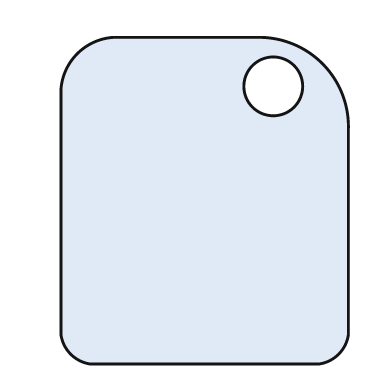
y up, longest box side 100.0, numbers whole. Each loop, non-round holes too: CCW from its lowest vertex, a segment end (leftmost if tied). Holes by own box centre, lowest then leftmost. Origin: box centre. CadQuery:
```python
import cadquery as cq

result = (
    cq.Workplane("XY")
    .moveTo(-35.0, -50.0)
    .lineTo(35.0, -50.0)
    .threePointArc((41.0, -47.0), (44.0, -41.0))
    .lineTo(44.0, 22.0)
    .threePointArc((36.0, 42.0), (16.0, 50.0))
    .lineTo(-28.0, 50.0)
    .threePointArc((-39.0, 45.0), (-44.0, 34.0))
    .lineTo(-44.0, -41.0)
    .threePointArc((-41.0, -47.0), (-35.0, -50.0))
    .close()
    .moveTo(21.0, 35.0)
    .circle(9.0)
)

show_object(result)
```